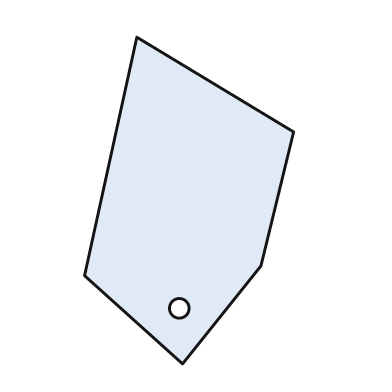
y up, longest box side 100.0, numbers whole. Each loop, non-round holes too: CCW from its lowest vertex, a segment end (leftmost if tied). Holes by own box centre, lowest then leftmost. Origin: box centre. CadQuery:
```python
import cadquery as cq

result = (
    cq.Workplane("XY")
    .moveTo(-2.0, -50.0)
    .lineTo(22.0, -20.0)
    .lineTo(32.0, 21.0)
    .lineTo(-16.0, 50.0)
    .lineTo(-32.0, -23.0)
    .close()
    .moveTo(-3.0, -33.0)
    .circle(3.0)
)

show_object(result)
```